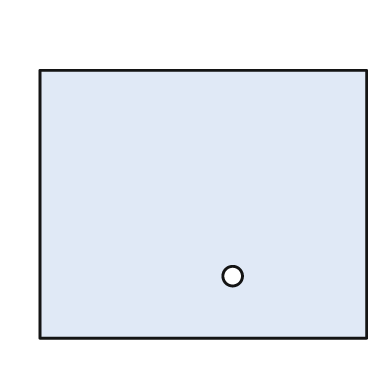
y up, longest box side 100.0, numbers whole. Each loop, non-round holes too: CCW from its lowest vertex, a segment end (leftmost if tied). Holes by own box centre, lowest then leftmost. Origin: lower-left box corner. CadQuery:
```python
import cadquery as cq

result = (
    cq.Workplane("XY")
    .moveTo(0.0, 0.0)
    .lineTo(100.0, 0.0)
    .lineTo(100.0, 82.0)
    .lineTo(0.0, 82.0)
    .close()
    .moveTo(59.0, 19.0)
    .circle(3.0)
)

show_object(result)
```